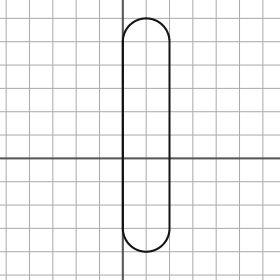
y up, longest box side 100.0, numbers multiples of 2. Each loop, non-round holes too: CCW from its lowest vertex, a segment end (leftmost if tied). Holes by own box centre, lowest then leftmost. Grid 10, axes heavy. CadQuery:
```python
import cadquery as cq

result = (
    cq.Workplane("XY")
    .moveTo(0.0, -30.0)
    .threePointArc((10.0, -40.0), (20.0, -30.0))
    .lineTo(20.0, 50.0)
    .threePointArc((10.0, 60.0), (0.0, 50.0))
    .close()
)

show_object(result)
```